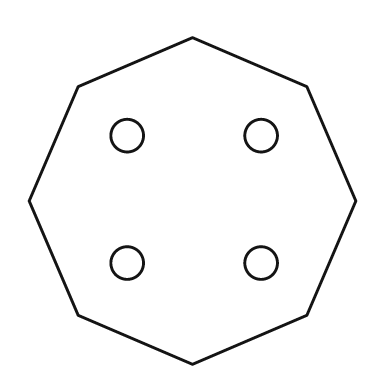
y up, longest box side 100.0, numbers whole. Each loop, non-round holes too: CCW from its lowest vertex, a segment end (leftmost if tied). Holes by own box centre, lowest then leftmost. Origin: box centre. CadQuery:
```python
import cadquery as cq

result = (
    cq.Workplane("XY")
    .moveTo(0.0, -50.0)
    .lineTo(35.0, -35.0)
    .lineTo(50.0, 0.0)
    .lineTo(35.0, 35.0)
    .lineTo(0.0, 50.0)
    .lineTo(-35.0, 35.0)
    .lineTo(-50.0, 0.0)
    .lineTo(-35.0, -35.0)
    .close()
    .moveTo(-20.0, -19.0)
    .circle(5.0)
    .moveTo(21.0, -19.0)
    .circle(5.0)
    .moveTo(-20.0, 20.0)
    .circle(5.0)
    .moveTo(21.0, 20.0)
    .circle(5.0)
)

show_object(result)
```